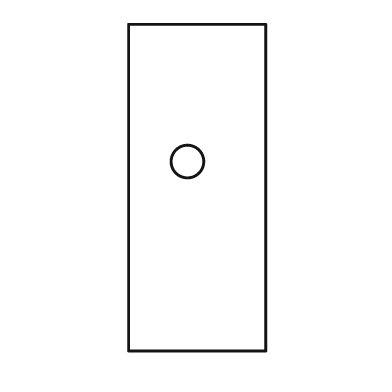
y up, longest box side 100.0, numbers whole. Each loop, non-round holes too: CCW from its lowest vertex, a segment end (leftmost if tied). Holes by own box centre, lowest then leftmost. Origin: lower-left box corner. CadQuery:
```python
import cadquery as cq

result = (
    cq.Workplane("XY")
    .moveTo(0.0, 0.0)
    .lineTo(42.0, 0.0)
    .lineTo(42.0, 100.0)
    .lineTo(0.0, 100.0)
    .close()
    .moveTo(18.0, 58.0)
    .circle(5.0)
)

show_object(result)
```